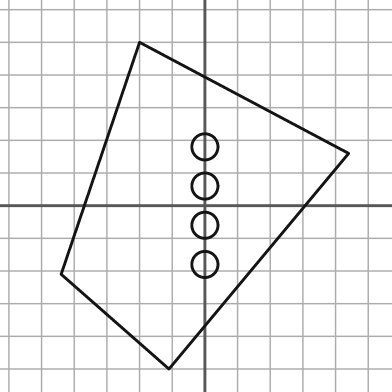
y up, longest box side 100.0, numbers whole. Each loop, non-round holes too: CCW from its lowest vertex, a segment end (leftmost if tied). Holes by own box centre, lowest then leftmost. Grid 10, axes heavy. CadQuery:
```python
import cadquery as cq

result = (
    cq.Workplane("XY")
    .moveTo(-11.0, -50.0)
    .lineTo(44.0, 16.0)
    .lineTo(-20.0, 50.0)
    .lineTo(-44.0, -21.0)
    .close()
    .moveTo(0.0, -18.0)
    .circle(4.0)
    .moveTo(0.0, -6.0)
    .circle(4.0)
    .moveTo(0.0, 6.0)
    .circle(4.0)
    .moveTo(0.0, 18.0)
    .circle(4.0)
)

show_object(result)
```